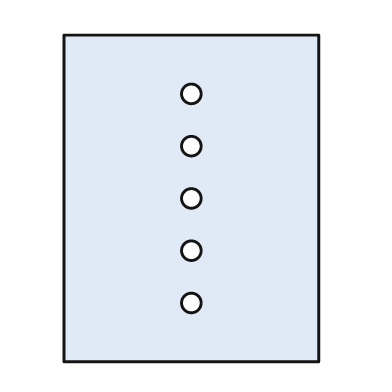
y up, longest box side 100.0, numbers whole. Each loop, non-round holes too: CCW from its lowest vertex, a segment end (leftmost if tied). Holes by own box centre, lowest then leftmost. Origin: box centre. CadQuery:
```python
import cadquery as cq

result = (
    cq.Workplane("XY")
    .moveTo(-39.0, -50.0)
    .lineTo(39.0, -50.0)
    .lineTo(39.0, 50.0)
    .lineTo(-39.0, 50.0)
    .close()
    .moveTo(0.0, -32.0)
    .circle(3.0)
    .moveTo(0.0, -16.0)
    .circle(3.0)
    .moveTo(0.0, 0.0)
    .circle(3.0)
    .moveTo(0.0, 16.0)
    .circle(3.0)
    .moveTo(0.0, 32.0)
    .circle(3.0)
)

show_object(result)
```